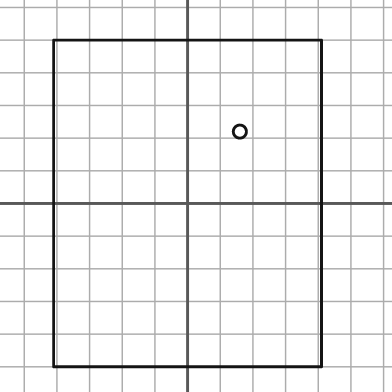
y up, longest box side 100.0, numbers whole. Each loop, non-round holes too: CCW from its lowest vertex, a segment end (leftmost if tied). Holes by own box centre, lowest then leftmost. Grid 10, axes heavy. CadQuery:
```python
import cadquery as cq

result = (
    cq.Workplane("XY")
    .moveTo(-41.0, -50.0)
    .lineTo(41.0, -50.0)
    .lineTo(41.0, 50.0)
    .lineTo(-41.0, 50.0)
    .close()
    .moveTo(16.0, 22.0)
    .circle(2.0)
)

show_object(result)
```